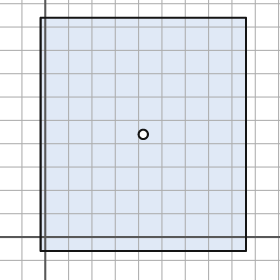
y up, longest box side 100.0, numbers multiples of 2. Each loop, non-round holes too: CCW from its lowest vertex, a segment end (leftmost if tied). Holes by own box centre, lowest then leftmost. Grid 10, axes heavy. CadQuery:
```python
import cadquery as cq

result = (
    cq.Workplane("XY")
    .moveTo(-2.0, -6.0)
    .lineTo(86.0, -6.0)
    .lineTo(86.0, 94.0)
    .lineTo(-2.0, 94.0)
    .close()
    .moveTo(42.0, 44.0)
    .circle(2.0)
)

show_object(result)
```